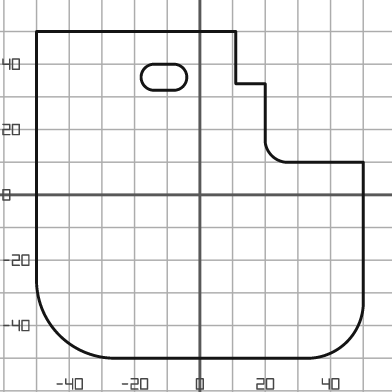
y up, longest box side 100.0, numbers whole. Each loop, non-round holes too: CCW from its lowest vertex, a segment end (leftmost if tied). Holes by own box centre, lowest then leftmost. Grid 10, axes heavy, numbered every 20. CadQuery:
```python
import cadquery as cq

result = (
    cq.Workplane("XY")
    .moveTo(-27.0, -50.0)
    .lineTo(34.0, -50.0)
    .threePointArc((45.0, -45.0), (50.0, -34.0))
    .lineTo(50.0, 10.0)
    .lineTo(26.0, 10.0)
    .threePointArc((22.0, 12.0), (20.0, 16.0))
    .lineTo(20.0, 34.0)
    .lineTo(11.0, 34.0)
    .lineTo(11.0, 50.0)
    .lineTo(-50.0, 50.0)
    .lineTo(-50.0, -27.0)
    .threePointArc((-43.0, -43.0), (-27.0, -50.0))
    .close()
    .moveTo(-14.0, 32.0)
    .lineTo(-8.0, 32.0)
    .threePointArc((-4.0, 36.0), (-8.0, 40.0))
    .lineTo(-14.0, 40.0)
    .threePointArc((-18.0, 36.0), (-14.0, 32.0))
    .close()
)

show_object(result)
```